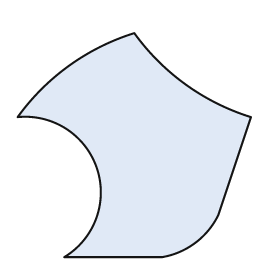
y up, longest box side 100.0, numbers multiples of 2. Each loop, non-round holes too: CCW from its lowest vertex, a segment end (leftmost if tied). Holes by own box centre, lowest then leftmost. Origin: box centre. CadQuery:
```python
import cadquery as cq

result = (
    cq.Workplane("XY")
    .moveTo(-30.0, -48.0)
    .lineTo(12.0, -48.0)
    .threePointArc((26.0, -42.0), (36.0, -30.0))
    .lineTo(50.0, 12.0)
    .threePointArc((22.0, 26.0), (0.0, 48.0))
    .threePointArc((-28.0, 34.0), (-50.0, 12.0))
    .threePointArc((-16.0, -10.0), (-30.0, -48.0))
    .close()
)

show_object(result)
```